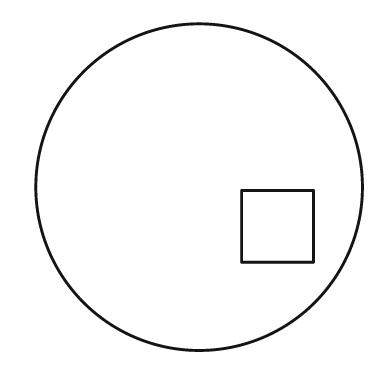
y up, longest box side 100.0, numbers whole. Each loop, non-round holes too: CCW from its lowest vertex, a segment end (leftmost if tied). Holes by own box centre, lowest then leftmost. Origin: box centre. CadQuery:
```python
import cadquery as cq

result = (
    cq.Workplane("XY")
    .moveTo(0.0, 0.0)
    .circle(50.0)
    .moveTo(13.0, -23.0)
    .lineTo(35.0, -23.0)
    .lineTo(35.0, -1.0)
    .lineTo(13.0, -1.0)
    .close()
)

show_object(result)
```